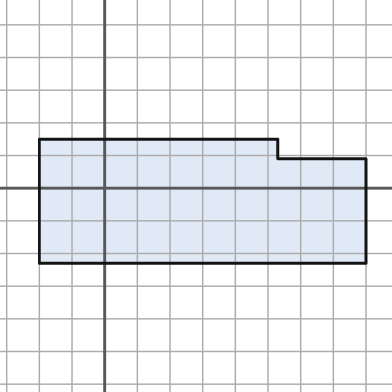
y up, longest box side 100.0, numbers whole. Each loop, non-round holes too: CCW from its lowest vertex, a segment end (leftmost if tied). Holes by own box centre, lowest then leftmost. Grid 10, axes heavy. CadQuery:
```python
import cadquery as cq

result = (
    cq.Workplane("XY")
    .moveTo(-20.0, -23.0)
    .lineTo(80.0, -23.0)
    .lineTo(80.0, 9.0)
    .lineTo(53.0, 9.0)
    .lineTo(53.0, 15.0)
    .lineTo(-20.0, 15.0)
    .close()
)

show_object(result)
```